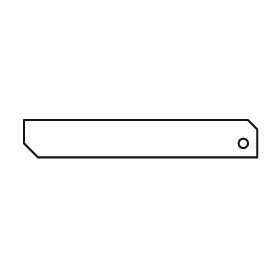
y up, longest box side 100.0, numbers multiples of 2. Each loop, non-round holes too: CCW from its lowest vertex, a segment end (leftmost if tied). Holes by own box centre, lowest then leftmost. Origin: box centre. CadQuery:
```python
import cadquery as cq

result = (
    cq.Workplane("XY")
    .moveTo(-44.0, -8.0)
    .lineTo(50.0, -8.0)
    .lineTo(50.0, 4.0)
    .lineTo(46.0, 8.0)
    .lineTo(-50.0, 8.0)
    .lineTo(-50.0, -2.0)
    .close()
    .moveTo(44.0, -2.0)
    .circle(2.0)
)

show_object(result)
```